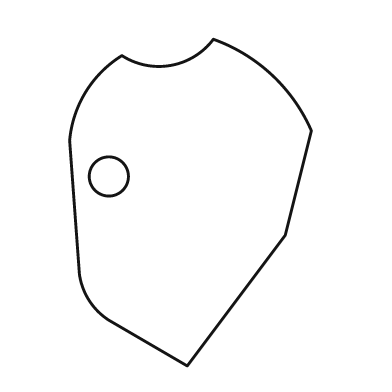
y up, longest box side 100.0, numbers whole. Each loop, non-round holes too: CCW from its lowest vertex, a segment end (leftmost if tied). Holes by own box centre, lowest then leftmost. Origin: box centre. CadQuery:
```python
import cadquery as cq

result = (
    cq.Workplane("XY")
    .moveTo(-1.0, -50.0)
    .lineTo(29.0, -10.0)
    .lineTo(37.0, 22.0)
    .threePointArc((25.0, 39.0), (7.0, 50.0))
    .threePointArc((-6.0, 42.0), (-21.0, 45.0))
    .threePointArc((-32.0, 34.0), (-37.0, 19.0))
    .lineTo(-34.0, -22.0)
    .threePointArc((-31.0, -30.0), (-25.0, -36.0))
    .close()
    .moveTo(-25.0, 8.0)
    .circle(6.0)
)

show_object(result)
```